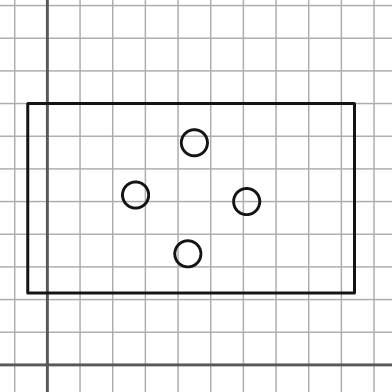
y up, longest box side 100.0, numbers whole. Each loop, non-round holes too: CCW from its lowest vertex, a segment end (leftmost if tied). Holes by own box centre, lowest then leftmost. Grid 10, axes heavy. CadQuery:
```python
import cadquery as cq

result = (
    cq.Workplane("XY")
    .moveTo(-6.0, 22.0)
    .lineTo(94.0, 22.0)
    .lineTo(94.0, 80.0)
    .lineTo(-6.0, 80.0)
    .close()
    .moveTo(43.0, 34.0)
    .circle(4.0)
    .moveTo(61.0, 50.0)
    .circle(4.0)
    .moveTo(27.0, 52.0)
    .circle(4.0)
    .moveTo(45.0, 68.0)
    .circle(4.0)
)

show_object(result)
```